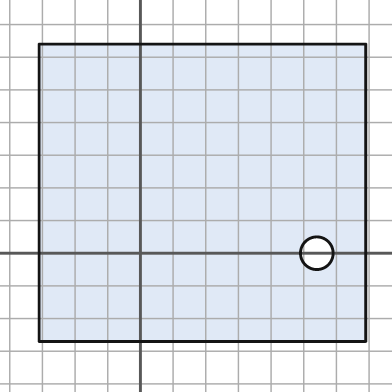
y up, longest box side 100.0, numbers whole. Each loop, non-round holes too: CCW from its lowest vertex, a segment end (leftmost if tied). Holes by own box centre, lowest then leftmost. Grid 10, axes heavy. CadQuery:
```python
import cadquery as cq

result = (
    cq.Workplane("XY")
    .moveTo(-31.0, -27.0)
    .lineTo(69.0, -27.0)
    .lineTo(69.0, 64.0)
    .lineTo(-31.0, 64.0)
    .close()
    .moveTo(54.0, 0.0)
    .circle(5.0)
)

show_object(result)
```